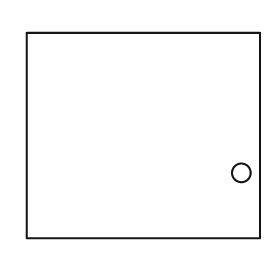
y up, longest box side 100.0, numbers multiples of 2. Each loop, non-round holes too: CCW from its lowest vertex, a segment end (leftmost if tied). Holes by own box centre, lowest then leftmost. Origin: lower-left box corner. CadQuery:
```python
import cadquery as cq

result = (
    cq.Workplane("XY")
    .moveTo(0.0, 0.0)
    .lineTo(100.0, 0.0)
    .lineTo(100.0, 88.0)
    .lineTo(0.0, 88.0)
    .close()
    .moveTo(92.0, 28.0)
    .circle(4.0)
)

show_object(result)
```